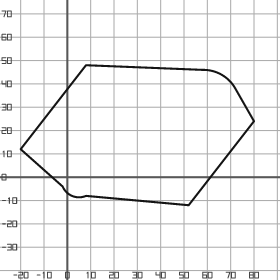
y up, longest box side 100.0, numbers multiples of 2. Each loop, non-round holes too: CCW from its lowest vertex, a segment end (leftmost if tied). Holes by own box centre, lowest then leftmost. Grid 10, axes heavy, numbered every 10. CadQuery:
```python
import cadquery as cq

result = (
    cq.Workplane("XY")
    .moveTo(52.0, -12.0)
    .lineTo(80.0, 24.0)
    .lineTo(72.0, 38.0)
    .threePointArc((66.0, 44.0), (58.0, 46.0))
    .lineTo(8.0, 48.0)
    .lineTo(-20.0, 12.0)
    .lineTo(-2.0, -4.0)
    .threePointArc((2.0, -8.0), (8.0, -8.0))
    .close()
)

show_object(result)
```